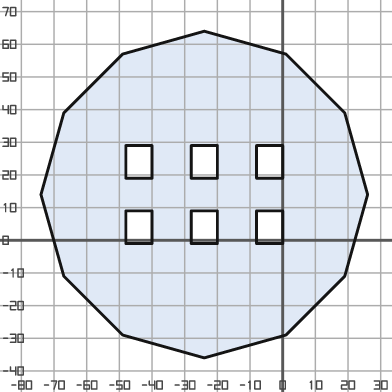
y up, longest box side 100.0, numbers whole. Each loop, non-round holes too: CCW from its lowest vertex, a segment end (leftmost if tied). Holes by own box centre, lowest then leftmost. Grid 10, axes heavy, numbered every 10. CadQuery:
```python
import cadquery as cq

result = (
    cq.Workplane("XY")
    .moveTo(-24.0, -36.0)
    .lineTo(1.0, -29.0)
    .lineTo(19.0, -11.0)
    .lineTo(26.0, 14.0)
    .lineTo(19.0, 39.0)
    .lineTo(1.0, 57.0)
    .lineTo(-24.0, 64.0)
    .lineTo(-49.0, 57.0)
    .lineTo(-67.0, 39.0)
    .lineTo(-74.0, 14.0)
    .lineTo(-67.0, -11.0)
    .lineTo(-49.0, -29.0)
    .close()
    .moveTo(-48.0, -1.0)
    .lineTo(-40.0, -1.0)
    .lineTo(-40.0, 9.0)
    .lineTo(-48.0, 9.0)
    .close()
    .moveTo(-28.0, -1.0)
    .lineTo(-20.0, -1.0)
    .lineTo(-20.0, 9.0)
    .lineTo(-28.0, 9.0)
    .close()
    .moveTo(-8.0, -1.0)
    .lineTo(0.0, -1.0)
    .lineTo(0.0, 9.0)
    .lineTo(-8.0, 9.0)
    .close()
    .moveTo(-48.0, 19.0)
    .lineTo(-40.0, 19.0)
    .lineTo(-40.0, 29.0)
    .lineTo(-48.0, 29.0)
    .close()
    .moveTo(-28.0, 19.0)
    .lineTo(-20.0, 19.0)
    .lineTo(-20.0, 29.0)
    .lineTo(-28.0, 29.0)
    .close()
    .moveTo(-8.0, 19.0)
    .lineTo(0.0, 19.0)
    .lineTo(0.0, 29.0)
    .lineTo(-8.0, 29.0)
    .close()
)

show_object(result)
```